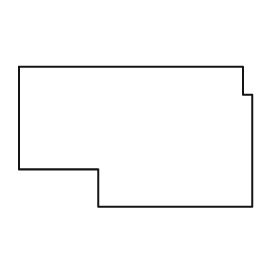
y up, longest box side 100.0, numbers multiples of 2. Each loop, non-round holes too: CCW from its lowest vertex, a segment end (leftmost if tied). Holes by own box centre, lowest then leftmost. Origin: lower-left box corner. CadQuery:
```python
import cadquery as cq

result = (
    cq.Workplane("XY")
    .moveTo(34.0, 0.0)
    .lineTo(100.0, 0.0)
    .lineTo(100.0, 48.0)
    .lineTo(96.0, 48.0)
    .lineTo(96.0, 60.0)
    .lineTo(0.0, 60.0)
    .lineTo(0.0, 16.0)
    .lineTo(34.0, 16.0)
    .close()
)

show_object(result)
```